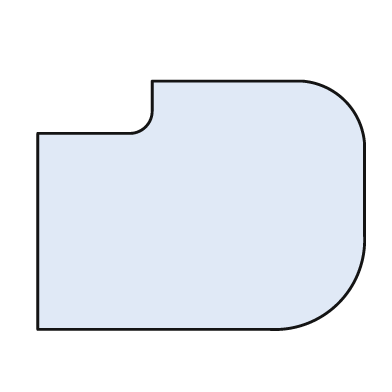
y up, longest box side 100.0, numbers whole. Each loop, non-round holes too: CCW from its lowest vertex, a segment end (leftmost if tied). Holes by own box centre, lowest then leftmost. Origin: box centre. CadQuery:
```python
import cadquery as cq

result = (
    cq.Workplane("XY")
    .moveTo(-50.0, -38.0)
    .lineTo(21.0, -38.0)
    .threePointArc((42.0, -30.0), (50.0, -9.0))
    .lineTo(50.0, 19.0)
    .threePointArc((44.0, 32.0), (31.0, 38.0))
    .lineTo(-15.0, 38.0)
    .lineTo(-15.0, 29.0)
    .threePointArc((-17.0, 24.0), (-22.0, 22.0))
    .lineTo(-50.0, 22.0)
    .close()
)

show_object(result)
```